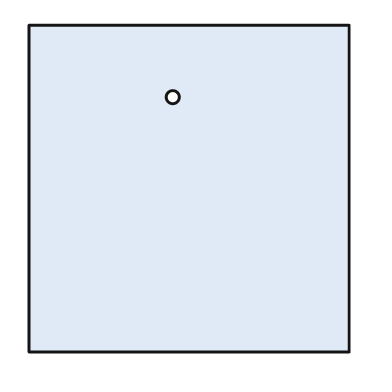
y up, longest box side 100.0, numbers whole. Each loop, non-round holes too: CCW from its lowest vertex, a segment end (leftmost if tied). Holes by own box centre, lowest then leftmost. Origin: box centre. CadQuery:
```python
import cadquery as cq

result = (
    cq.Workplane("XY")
    .moveTo(-49.0, -50.0)
    .lineTo(49.0, -50.0)
    .lineTo(49.0, 50.0)
    .lineTo(-49.0, 50.0)
    .close()
    .moveTo(-5.0, 28.0)
    .circle(2.0)
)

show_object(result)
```